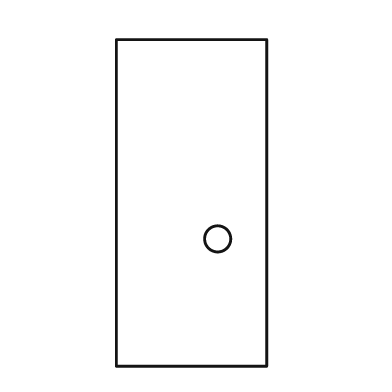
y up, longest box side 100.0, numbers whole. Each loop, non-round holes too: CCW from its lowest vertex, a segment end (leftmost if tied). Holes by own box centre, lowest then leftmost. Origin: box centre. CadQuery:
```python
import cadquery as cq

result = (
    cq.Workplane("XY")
    .moveTo(-23.0, -50.0)
    .lineTo(23.0, -50.0)
    .lineTo(23.0, 50.0)
    .lineTo(-23.0, 50.0)
    .close()
    .moveTo(8.0, -11.0)
    .circle(4.0)
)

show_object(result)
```